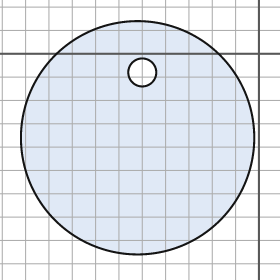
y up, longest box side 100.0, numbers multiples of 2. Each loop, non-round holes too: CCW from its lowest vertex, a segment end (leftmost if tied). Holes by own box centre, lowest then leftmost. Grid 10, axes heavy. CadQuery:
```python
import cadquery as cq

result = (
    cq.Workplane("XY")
    .moveTo(-52.0, -36.0)
    .circle(50.0)
    .moveTo(-50.0, -8.0)
    .circle(6.0)
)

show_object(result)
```